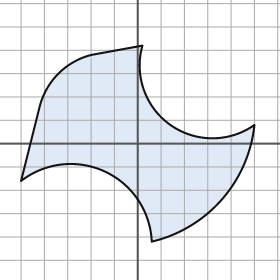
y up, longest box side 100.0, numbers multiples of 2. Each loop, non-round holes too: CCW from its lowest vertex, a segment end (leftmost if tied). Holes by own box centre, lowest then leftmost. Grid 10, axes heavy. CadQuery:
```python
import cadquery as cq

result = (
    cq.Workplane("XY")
    .moveTo(6.0, -42.0)
    .threePointArc((36.0, -24.0), (50.0, 8.0))
    .threePointArc((14.0, 8.0), (2.0, 42.0))
    .lineTo(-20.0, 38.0)
    .threePointArc((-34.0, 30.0), (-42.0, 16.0))
    .lineTo(-50.0, -16.0)
    .threePointArc((-14.0, -12.0), (6.0, -42.0))
    .close()
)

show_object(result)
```